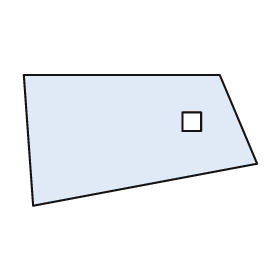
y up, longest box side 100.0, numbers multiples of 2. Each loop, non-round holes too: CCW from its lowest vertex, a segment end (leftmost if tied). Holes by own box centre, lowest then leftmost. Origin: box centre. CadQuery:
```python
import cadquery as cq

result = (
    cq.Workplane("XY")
    .moveTo(-46.0, -28.0)
    .lineTo(50.0, -10.0)
    .lineTo(34.0, 28.0)
    .lineTo(-50.0, 28.0)
    .close()
    .moveTo(18.0, 4.0)
    .lineTo(26.0, 4.0)
    .lineTo(26.0, 12.0)
    .lineTo(18.0, 12.0)
    .close()
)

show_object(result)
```